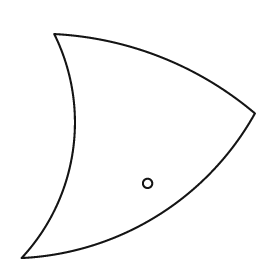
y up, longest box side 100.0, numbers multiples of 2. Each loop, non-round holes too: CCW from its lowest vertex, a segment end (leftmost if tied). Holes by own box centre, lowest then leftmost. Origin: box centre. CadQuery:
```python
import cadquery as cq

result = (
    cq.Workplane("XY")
    .moveTo(-50.0, -48.0)
    .threePointArc((8.0, -30.0), (50.0, 14.0))
    .threePointArc((10.0, 38.0), (-36.0, 48.0))
    .threePointArc((-28.0, -2.0), (-50.0, -48.0))
    .close()
    .moveTo(4.0, -16.0)
    .circle(2.0)
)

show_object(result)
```